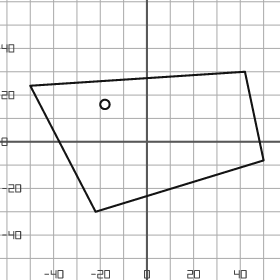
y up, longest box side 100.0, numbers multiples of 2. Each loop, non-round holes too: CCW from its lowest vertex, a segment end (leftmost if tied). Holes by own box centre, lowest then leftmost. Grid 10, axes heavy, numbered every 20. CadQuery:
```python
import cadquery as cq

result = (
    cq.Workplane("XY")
    .moveTo(-22.0, -30.0)
    .lineTo(50.0, -8.0)
    .lineTo(42.0, 30.0)
    .lineTo(-50.0, 24.0)
    .close()
    .moveTo(-18.0, 16.0)
    .circle(2.0)
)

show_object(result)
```